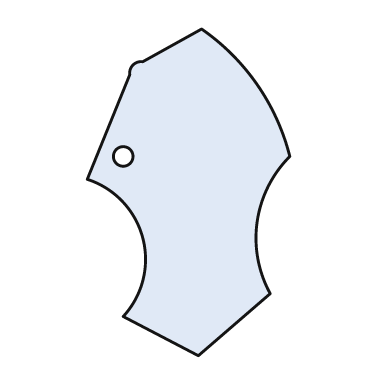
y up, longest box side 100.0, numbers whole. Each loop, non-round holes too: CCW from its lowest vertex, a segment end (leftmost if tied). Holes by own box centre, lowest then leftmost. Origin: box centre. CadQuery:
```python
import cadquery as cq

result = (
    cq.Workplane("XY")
    .moveTo(3.0, -50.0)
    .lineTo(25.0, -31.0)
    .threePointArc((21.0, -9.0), (31.0, 11.0))
    .threePointArc((21.0, 33.0), (4.0, 50.0))
    .lineTo(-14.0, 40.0)
    .threePointArc((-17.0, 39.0), (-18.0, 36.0))
    .lineTo(-31.0, 4.0)
    .threePointArc((-14.0, -14.0), (-20.0, -38.0))
    .close()
    .moveTo(-20.0, 11.0)
    .circle(3.0)
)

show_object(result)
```